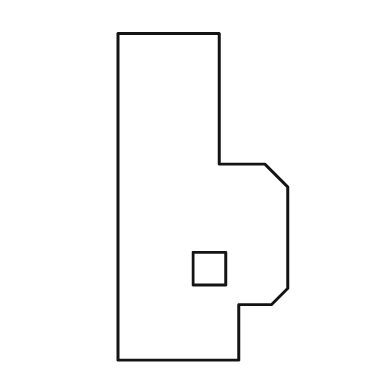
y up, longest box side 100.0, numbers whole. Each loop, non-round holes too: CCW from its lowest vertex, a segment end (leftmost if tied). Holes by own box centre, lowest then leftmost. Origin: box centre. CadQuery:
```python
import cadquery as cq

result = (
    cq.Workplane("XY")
    .moveTo(-26.0, -50.0)
    .lineTo(11.0, -50.0)
    .lineTo(11.0, -33.0)
    .lineTo(21.0, -33.0)
    .lineTo(26.0, -28.0)
    .lineTo(26.0, 3.0)
    .lineTo(19.0, 10.0)
    .lineTo(5.0, 10.0)
    .lineTo(5.0, 50.0)
    .lineTo(-26.0, 50.0)
    .close()
    .moveTo(-3.0, -27.0)
    .lineTo(7.0, -27.0)
    .lineTo(7.0, -17.0)
    .lineTo(-3.0, -17.0)
    .close()
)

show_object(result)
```